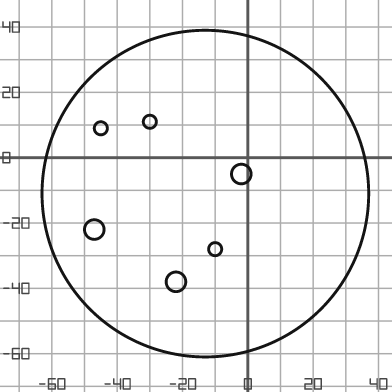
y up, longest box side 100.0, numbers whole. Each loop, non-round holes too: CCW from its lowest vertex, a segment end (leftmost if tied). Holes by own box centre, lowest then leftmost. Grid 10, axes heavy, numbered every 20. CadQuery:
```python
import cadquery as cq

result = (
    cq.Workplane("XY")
    .moveTo(-13.0, -11.0)
    .circle(50.0)
    .moveTo(-22.0, -38.0)
    .circle(3.0)
    .moveTo(-10.0, -28.0)
    .circle(2.0)
    .moveTo(-47.0, -22.0)
    .circle(3.0)
    .moveTo(-2.0, -5.0)
    .circle(3.0)
    .moveTo(-45.0, 9.0)
    .circle(2.0)
    .moveTo(-30.0, 11.0)
    .circle(2.0)
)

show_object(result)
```